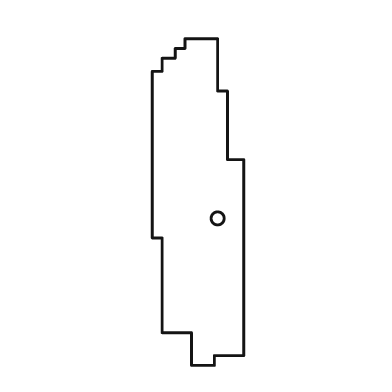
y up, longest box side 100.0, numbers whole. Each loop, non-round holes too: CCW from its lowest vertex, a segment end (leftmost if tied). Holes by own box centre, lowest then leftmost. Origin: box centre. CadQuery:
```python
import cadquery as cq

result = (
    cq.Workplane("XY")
    .moveTo(-2.0, -50.0)
    .lineTo(5.0, -50.0)
    .lineTo(5.0, -47.0)
    .lineTo(14.0, -47.0)
    .lineTo(14.0, 13.0)
    .lineTo(9.0, 13.0)
    .lineTo(9.0, 34.0)
    .lineTo(6.0, 34.0)
    .lineTo(6.0, 50.0)
    .lineTo(-4.0, 50.0)
    .lineTo(-4.0, 47.0)
    .lineTo(-7.0, 47.0)
    .lineTo(-7.0, 44.0)
    .lineTo(-11.0, 44.0)
    .lineTo(-11.0, 40.0)
    .lineTo(-14.0, 40.0)
    .lineTo(-14.0, -11.0)
    .lineTo(-11.0, -11.0)
    .lineTo(-11.0, -40.0)
    .lineTo(-2.0, -40.0)
    .close()
    .moveTo(6.0, -5.0)
    .circle(2.0)
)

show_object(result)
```